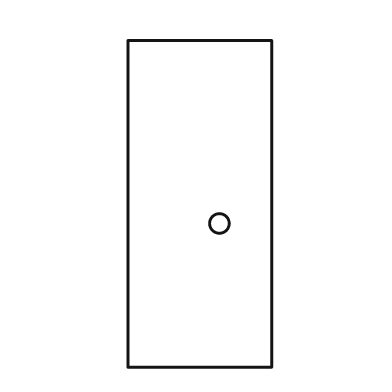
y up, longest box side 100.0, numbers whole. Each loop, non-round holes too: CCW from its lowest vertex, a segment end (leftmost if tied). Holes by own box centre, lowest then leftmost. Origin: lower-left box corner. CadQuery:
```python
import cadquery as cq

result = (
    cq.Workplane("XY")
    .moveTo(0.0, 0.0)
    .lineTo(44.0, 0.0)
    .lineTo(44.0, 100.0)
    .lineTo(0.0, 100.0)
    .close()
    .moveTo(28.0, 44.0)
    .circle(3.0)
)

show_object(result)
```